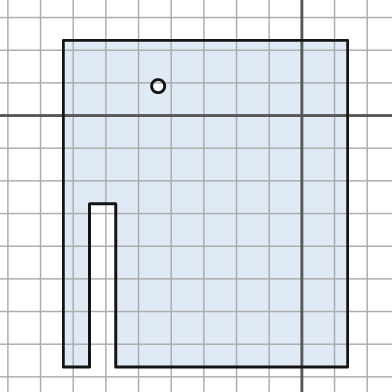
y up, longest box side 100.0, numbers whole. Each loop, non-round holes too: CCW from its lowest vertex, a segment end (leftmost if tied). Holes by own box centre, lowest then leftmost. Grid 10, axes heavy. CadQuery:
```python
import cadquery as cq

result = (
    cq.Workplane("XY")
    .moveTo(-73.0, -77.0)
    .lineTo(-65.0, -77.0)
    .lineTo(-65.0, -27.0)
    .lineTo(-57.0, -27.0)
    .lineTo(-57.0, -77.0)
    .lineTo(14.0, -77.0)
    .lineTo(14.0, 23.0)
    .lineTo(-73.0, 23.0)
    .close()
    .moveTo(-44.0, 9.0)
    .circle(2.0)
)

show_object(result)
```